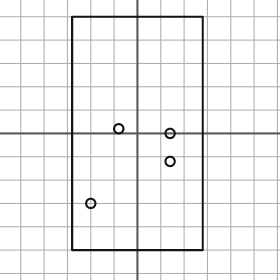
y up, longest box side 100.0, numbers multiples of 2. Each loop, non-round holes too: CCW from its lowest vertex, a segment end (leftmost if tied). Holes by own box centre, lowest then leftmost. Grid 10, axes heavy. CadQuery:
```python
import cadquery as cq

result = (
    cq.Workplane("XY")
    .moveTo(-28.0, -50.0)
    .lineTo(28.0, -50.0)
    .lineTo(28.0, 50.0)
    .lineTo(-28.0, 50.0)
    .close()
    .moveTo(-20.0, -30.0)
    .circle(2.0)
    .moveTo(14.0, -12.0)
    .circle(2.0)
    .moveTo(14.0, 0.0)
    .circle(2.0)
    .moveTo(-8.0, 2.0)
    .circle(2.0)
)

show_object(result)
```